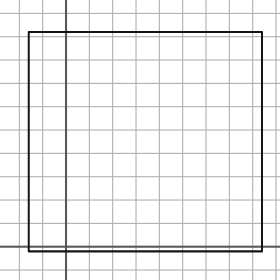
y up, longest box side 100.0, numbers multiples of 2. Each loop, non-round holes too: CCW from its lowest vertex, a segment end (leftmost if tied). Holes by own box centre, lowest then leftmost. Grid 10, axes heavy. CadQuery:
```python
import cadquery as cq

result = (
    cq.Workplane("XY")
    .moveTo(-16.0, -2.0)
    .lineTo(84.0, -2.0)
    .lineTo(84.0, 92.0)
    .lineTo(-16.0, 92.0)
    .close()
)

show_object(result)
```